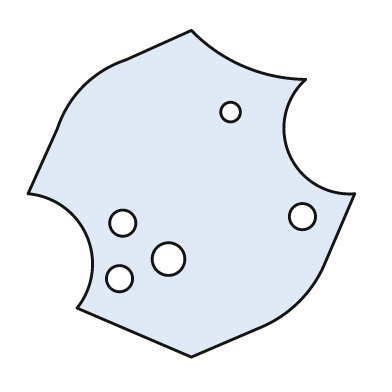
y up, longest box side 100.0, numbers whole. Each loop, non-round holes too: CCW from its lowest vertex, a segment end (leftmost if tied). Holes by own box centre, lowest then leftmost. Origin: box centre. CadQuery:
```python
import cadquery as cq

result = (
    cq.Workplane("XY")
    .moveTo(0.0, -50.0)
    .lineTo(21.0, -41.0)
    .threePointArc((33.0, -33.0), (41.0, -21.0))
    .lineTo(50.0, 0.0)
    .threePointArc((30.0, 12.0), (35.0, 35.0))
    .threePointArc((16.0, 39.0), (0.0, 50.0))
    .lineTo(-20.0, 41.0)
    .threePointArc((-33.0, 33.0), (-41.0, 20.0))
    .lineTo(-50.0, 0.0)
    .threePointArc((-32.0, -13.0), (-35.0, -35.0))
    .close()
    .moveTo(-22.0, -26.0)
    .circle(4.0)
    .moveTo(-7.0, -20.0)
    .circle(5.0)
    .moveTo(-21.0, -9.0)
    .circle(4.0)
    .moveTo(34.0, -7.0)
    .circle(4.0)
    .moveTo(12.0, 25.0)
    .circle(3.0)
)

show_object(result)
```